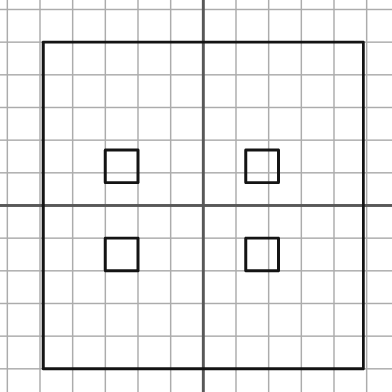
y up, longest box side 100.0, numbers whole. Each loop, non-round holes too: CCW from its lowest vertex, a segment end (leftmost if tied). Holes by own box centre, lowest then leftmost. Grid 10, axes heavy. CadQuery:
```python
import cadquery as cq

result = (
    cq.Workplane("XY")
    .moveTo(-49.0, -50.0)
    .lineTo(49.0, -50.0)
    .lineTo(49.0, 50.0)
    .lineTo(-49.0, 50.0)
    .close()
    .moveTo(-30.0, -20.0)
    .lineTo(-20.0, -20.0)
    .lineTo(-20.0, -10.0)
    .lineTo(-30.0, -10.0)
    .close()
    .moveTo(13.0, -20.0)
    .lineTo(23.0, -20.0)
    .lineTo(23.0, -10.0)
    .lineTo(13.0, -10.0)
    .close()
    .moveTo(-30.0, 7.0)
    .lineTo(-20.0, 7.0)
    .lineTo(-20.0, 17.0)
    .lineTo(-30.0, 17.0)
    .close()
    .moveTo(13.0, 7.0)
    .lineTo(23.0, 7.0)
    .lineTo(23.0, 17.0)
    .lineTo(13.0, 17.0)
    .close()
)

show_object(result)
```